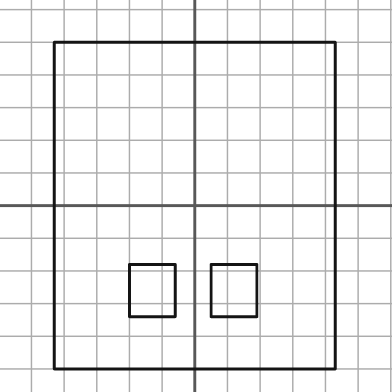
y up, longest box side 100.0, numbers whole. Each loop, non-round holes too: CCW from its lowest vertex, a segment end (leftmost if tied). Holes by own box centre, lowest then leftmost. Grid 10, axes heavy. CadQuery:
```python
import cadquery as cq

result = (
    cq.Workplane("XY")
    .moveTo(-43.0, -50.0)
    .lineTo(43.0, -50.0)
    .lineTo(43.0, 50.0)
    .lineTo(-43.0, 50.0)
    .close()
    .moveTo(-20.0, -34.0)
    .lineTo(-6.0, -34.0)
    .lineTo(-6.0, -18.0)
    .lineTo(-20.0, -18.0)
    .close()
    .moveTo(5.0, -34.0)
    .lineTo(19.0, -34.0)
    .lineTo(19.0, -18.0)
    .lineTo(5.0, -18.0)
    .close()
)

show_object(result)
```